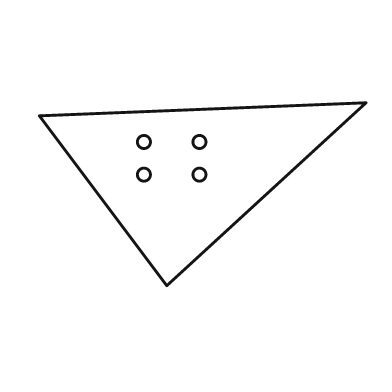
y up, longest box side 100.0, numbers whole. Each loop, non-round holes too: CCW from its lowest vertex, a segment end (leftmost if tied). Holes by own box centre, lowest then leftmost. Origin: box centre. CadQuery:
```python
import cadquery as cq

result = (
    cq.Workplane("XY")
    .moveTo(-11.0, -28.0)
    .lineTo(50.0, 28.0)
    .lineTo(-50.0, 24.0)
    .close()
    .moveTo(-18.0, 6.0)
    .circle(2.0)
    .moveTo(-1.0, 6.0)
    .circle(2.0)
    .moveTo(-18.0, 16.0)
    .circle(2.0)
    .moveTo(-1.0, 16.0)
    .circle(2.0)
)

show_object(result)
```